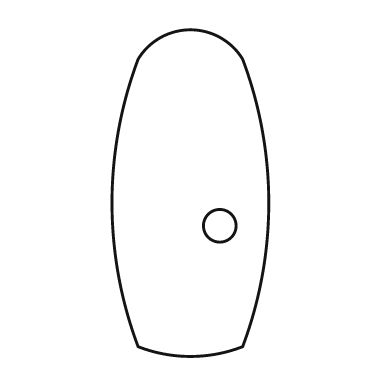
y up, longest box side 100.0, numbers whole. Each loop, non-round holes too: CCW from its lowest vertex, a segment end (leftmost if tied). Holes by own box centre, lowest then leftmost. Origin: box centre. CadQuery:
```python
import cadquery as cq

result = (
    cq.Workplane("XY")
    .moveTo(-16.0, -47.0)
    .threePointArc((0.0, -50.0), (16.0, -47.0))
    .threePointArc((24.0, -3.0), (16.0, 41.0))
    .threePointArc((0.0, 50.0), (-16.0, 41.0))
    .threePointArc((-24.0, -3.0), (-16.0, -47.0))
    .close()
    .moveTo(9.0, -10.0)
    .circle(5.0)
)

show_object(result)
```